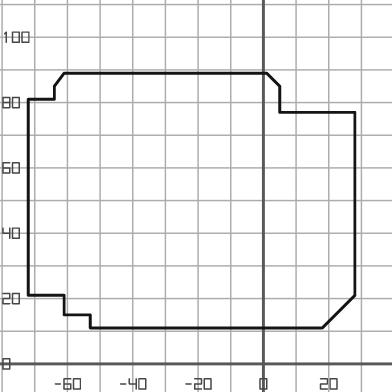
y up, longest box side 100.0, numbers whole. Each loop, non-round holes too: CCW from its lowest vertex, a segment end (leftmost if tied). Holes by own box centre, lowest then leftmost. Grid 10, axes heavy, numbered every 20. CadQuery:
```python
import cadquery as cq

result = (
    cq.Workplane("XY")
    .moveTo(-53.0, 11.0)
    .lineTo(18.0, 11.0)
    .lineTo(28.0, 21.0)
    .lineTo(28.0, 77.0)
    .lineTo(5.0, 77.0)
    .lineTo(5.0, 85.0)
    .lineTo(1.0, 89.0)
    .lineTo(-61.0, 89.0)
    .lineTo(-64.0, 85.0)
    .lineTo(-64.0, 81.0)
    .lineTo(-72.0, 81.0)
    .lineTo(-72.0, 21.0)
    .lineTo(-61.0, 21.0)
    .lineTo(-61.0, 15.0)
    .lineTo(-53.0, 15.0)
    .close()
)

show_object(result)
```